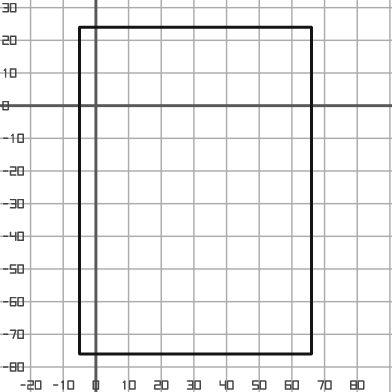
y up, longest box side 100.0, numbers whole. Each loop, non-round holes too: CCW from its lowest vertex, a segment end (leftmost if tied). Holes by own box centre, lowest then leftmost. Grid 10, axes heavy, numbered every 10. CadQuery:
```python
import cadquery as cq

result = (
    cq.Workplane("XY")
    .moveTo(-5.0, -76.0)
    .lineTo(66.0, -76.0)
    .lineTo(66.0, 24.0)
    .lineTo(-5.0, 24.0)
    .close()
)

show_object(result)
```